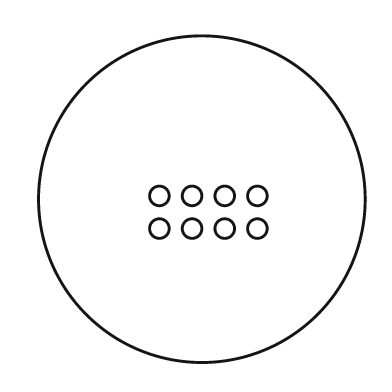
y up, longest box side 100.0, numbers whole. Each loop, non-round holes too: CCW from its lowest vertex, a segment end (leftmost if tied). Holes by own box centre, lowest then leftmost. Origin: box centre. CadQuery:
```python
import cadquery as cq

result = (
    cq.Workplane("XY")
    .moveTo(0.0, 0.0)
    .circle(50.0)
    .moveTo(-13.0, -9.0)
    .circle(3.0)
    .moveTo(-3.0, -9.0)
    .circle(3.0)
    .moveTo(7.0, -9.0)
    .circle(3.0)
    .moveTo(17.0, -9.0)
    .circle(3.0)
    .moveTo(-13.0, 1.0)
    .circle(3.0)
    .moveTo(-3.0, 1.0)
    .circle(3.0)
    .moveTo(7.0, 1.0)
    .circle(3.0)
    .moveTo(17.0, 1.0)
    .circle(3.0)
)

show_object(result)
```